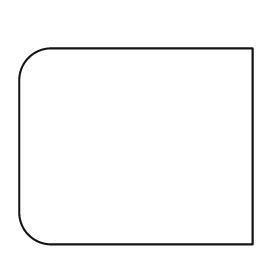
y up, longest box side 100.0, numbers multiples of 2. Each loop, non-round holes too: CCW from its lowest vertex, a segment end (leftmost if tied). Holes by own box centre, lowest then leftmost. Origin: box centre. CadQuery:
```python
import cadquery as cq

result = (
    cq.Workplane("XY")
    .moveTo(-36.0, -42.0)
    .lineTo(50.0, -42.0)
    .lineTo(50.0, 42.0)
    .lineTo(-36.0, 42.0)
    .threePointArc((-46.0, 38.0), (-50.0, 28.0))
    .lineTo(-50.0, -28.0)
    .threePointArc((-46.0, -38.0), (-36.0, -42.0))
    .close()
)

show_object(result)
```